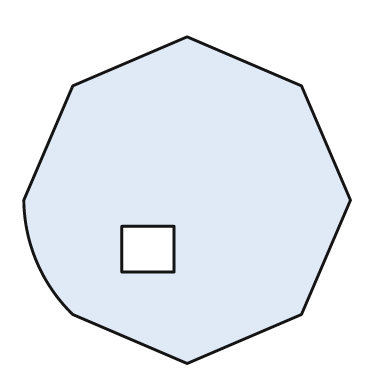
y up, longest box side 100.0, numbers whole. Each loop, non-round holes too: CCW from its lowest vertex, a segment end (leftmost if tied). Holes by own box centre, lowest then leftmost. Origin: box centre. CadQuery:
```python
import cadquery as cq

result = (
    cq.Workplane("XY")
    .moveTo(0.0, -50.0)
    .lineTo(35.0, -35.0)
    .lineTo(50.0, 0.0)
    .lineTo(35.0, 35.0)
    .lineTo(0.0, 50.0)
    .lineTo(-35.0, 35.0)
    .lineTo(-50.0, 0.0)
    .threePointArc((-46.0, -19.0), (-35.0, -35.0))
    .close()
    .moveTo(-20.0, -22.0)
    .lineTo(-4.0, -22.0)
    .lineTo(-4.0, -8.0)
    .lineTo(-20.0, -8.0)
    .close()
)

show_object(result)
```